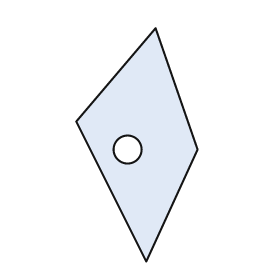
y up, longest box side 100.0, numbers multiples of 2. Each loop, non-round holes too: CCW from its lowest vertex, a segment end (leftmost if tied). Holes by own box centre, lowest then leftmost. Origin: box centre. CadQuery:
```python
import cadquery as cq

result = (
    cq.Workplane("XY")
    .moveTo(4.0, -50.0)
    .lineTo(26.0, -2.0)
    .lineTo(8.0, 50.0)
    .lineTo(-26.0, 10.0)
    .close()
    .moveTo(-4.0, -2.0)
    .circle(6.0)
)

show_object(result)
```